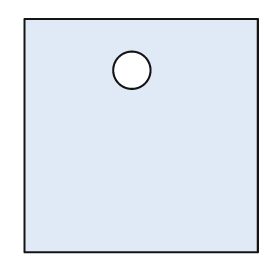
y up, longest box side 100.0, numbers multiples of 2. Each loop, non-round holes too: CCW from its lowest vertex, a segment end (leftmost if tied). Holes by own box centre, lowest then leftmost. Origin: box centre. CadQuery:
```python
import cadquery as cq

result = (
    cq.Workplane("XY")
    .moveTo(-50.0, -50.0)
    .lineTo(50.0, -50.0)
    .lineTo(50.0, 50.0)
    .lineTo(-50.0, 50.0)
    .close()
    .moveTo(-4.0, 28.0)
    .circle(8.0)
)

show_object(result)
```